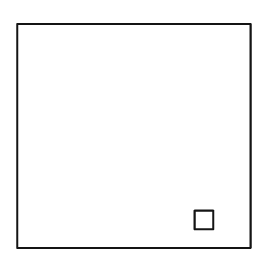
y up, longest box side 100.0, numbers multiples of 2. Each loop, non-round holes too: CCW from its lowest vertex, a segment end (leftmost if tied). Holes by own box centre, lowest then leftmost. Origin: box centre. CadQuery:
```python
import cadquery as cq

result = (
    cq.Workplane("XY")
    .moveTo(-50.0, -48.0)
    .lineTo(50.0, -48.0)
    .lineTo(50.0, 48.0)
    .lineTo(-50.0, 48.0)
    .close()
    .moveTo(26.0, -40.0)
    .lineTo(34.0, -40.0)
    .lineTo(34.0, -32.0)
    .lineTo(26.0, -32.0)
    .close()
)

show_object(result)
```